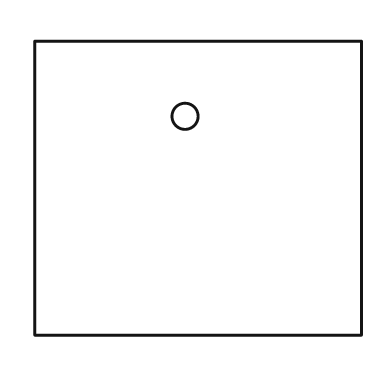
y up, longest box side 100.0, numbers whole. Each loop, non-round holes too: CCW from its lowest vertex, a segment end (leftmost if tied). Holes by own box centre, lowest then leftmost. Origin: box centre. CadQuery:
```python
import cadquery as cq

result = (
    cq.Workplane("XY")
    .moveTo(-50.0, -45.0)
    .lineTo(50.0, -45.0)
    .lineTo(50.0, 45.0)
    .lineTo(-50.0, 45.0)
    .close()
    .moveTo(-4.0, 22.0)
    .circle(4.0)
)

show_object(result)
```